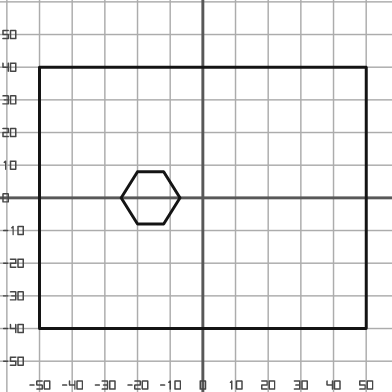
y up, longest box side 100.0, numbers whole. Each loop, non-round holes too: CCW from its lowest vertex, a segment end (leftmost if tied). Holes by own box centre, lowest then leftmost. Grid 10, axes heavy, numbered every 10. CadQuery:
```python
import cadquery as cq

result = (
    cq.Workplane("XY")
    .moveTo(-50.0, -40.0)
    .lineTo(50.0, -40.0)
    .lineTo(50.0, 40.0)
    .lineTo(-50.0, 40.0)
    .close()
    .moveTo(-20.0, -8.0)
    .lineTo(-12.0, -8.0)
    .lineTo(-7.0, 0.0)
    .lineTo(-12.0, 8.0)
    .lineTo(-20.0, 8.0)
    .lineTo(-25.0, 0.0)
    .close()
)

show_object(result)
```